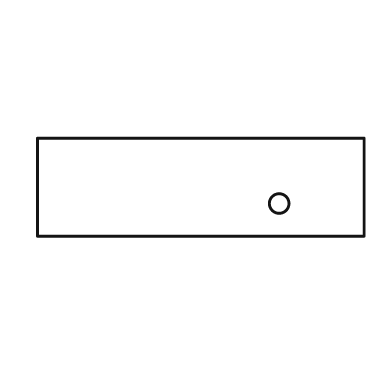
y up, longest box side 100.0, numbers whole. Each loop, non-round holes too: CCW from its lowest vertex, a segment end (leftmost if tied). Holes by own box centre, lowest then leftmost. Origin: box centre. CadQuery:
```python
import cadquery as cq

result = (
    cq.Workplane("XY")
    .moveTo(-50.0, -15.0)
    .lineTo(50.0, -15.0)
    .lineTo(50.0, 15.0)
    .lineTo(-50.0, 15.0)
    .close()
    .moveTo(24.0, -5.0)
    .circle(3.0)
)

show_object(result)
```